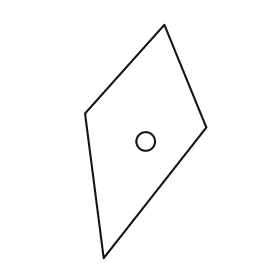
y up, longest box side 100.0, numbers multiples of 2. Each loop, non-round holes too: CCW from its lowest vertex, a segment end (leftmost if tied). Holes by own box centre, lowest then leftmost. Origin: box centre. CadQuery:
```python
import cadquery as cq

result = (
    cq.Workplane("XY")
    .moveTo(-18.0, -50.0)
    .lineTo(26.0, 6.0)
    .lineTo(8.0, 50.0)
    .lineTo(-26.0, 12.0)
    .close()
    .moveTo(0.0, 0.0)
    .circle(4.0)
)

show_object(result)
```